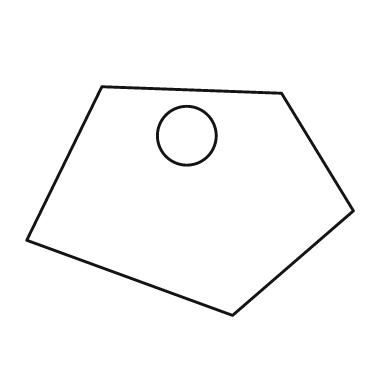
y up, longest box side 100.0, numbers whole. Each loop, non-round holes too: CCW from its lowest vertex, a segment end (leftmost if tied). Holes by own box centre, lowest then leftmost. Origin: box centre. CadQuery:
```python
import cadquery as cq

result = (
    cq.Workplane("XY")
    .moveTo(13.0, -35.0)
    .lineTo(50.0, -3.0)
    .lineTo(28.0, 33.0)
    .lineTo(-27.0, 35.0)
    .lineTo(-50.0, -12.0)
    .close()
    .moveTo(-1.0, 20.0)
    .circle(9.0)
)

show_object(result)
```